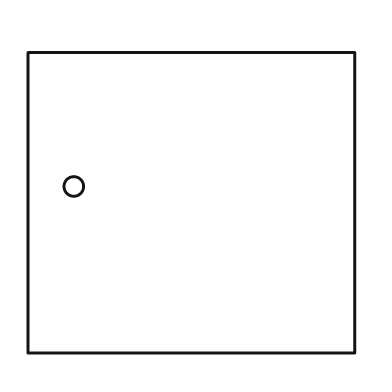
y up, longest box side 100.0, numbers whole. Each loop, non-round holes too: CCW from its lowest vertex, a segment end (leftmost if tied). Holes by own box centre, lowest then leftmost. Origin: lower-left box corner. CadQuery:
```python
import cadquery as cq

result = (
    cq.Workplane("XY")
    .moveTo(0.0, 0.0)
    .lineTo(100.0, 0.0)
    .lineTo(100.0, 92.0)
    .lineTo(0.0, 92.0)
    .close()
    .moveTo(14.0, 51.0)
    .circle(3.0)
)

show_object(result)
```